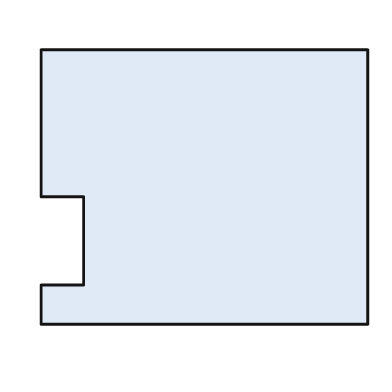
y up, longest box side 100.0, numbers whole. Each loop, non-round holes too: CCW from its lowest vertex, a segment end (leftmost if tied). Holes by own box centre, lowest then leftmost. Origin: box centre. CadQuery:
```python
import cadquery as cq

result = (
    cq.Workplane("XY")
    .moveTo(-50.0, -42.0)
    .lineTo(50.0, -42.0)
    .lineTo(50.0, 42.0)
    .lineTo(-50.0, 42.0)
    .lineTo(-50.0, -3.0)
    .lineTo(-37.0, -3.0)
    .lineTo(-37.0, -30.0)
    .lineTo(-50.0, -30.0)
    .close()
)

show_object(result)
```